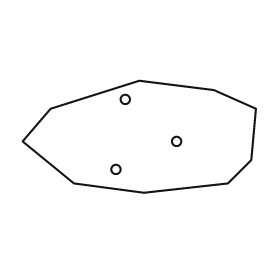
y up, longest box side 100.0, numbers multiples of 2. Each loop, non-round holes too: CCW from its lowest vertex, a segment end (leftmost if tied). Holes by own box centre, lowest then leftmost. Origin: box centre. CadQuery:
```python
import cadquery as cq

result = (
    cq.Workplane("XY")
    .moveTo(2.0, -24.0)
    .lineTo(38.0, -20.0)
    .lineTo(48.0, -10.0)
    .lineTo(50.0, 12.0)
    .lineTo(32.0, 20.0)
    .lineTo(0.0, 24.0)
    .lineTo(-38.0, 12.0)
    .lineTo(-50.0, -2.0)
    .lineTo(-28.0, -20.0)
    .close()
    .moveTo(-10.0, -14.0)
    .circle(2.0)
    .moveTo(16.0, -2.0)
    .circle(2.0)
    .moveTo(-6.0, 16.0)
    .circle(2.0)
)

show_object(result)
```